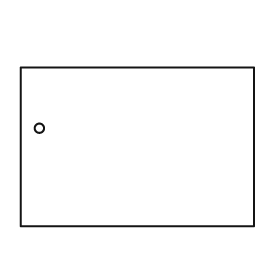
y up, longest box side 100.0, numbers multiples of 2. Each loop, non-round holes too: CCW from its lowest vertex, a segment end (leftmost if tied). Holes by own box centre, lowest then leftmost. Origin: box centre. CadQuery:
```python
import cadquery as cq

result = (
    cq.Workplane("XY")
    .moveTo(-50.0, -34.0)
    .lineTo(50.0, -34.0)
    .lineTo(50.0, 34.0)
    .lineTo(-50.0, 34.0)
    .close()
    .moveTo(-42.0, 8.0)
    .circle(2.0)
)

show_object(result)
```